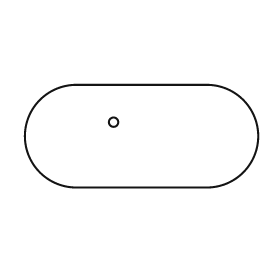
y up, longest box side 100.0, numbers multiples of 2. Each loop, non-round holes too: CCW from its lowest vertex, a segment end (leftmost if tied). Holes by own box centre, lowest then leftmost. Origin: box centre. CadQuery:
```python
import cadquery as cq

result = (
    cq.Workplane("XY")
    .moveTo(-28.0, -22.0)
    .lineTo(28.0, -22.0)
    .threePointArc((50.0, 0.0), (28.0, 22.0))
    .lineTo(-28.0, 22.0)
    .threePointArc((-50.0, 0.0), (-28.0, -22.0))
    .close()
    .moveTo(-12.0, 6.0)
    .circle(2.0)
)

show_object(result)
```